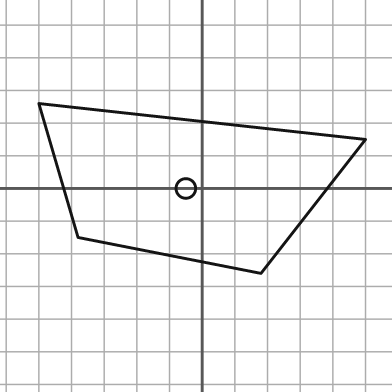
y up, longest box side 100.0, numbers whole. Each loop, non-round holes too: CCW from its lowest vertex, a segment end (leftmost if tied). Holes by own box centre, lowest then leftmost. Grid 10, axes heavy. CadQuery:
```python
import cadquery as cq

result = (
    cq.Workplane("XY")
    .moveTo(18.0, -26.0)
    .lineTo(50.0, 15.0)
    .lineTo(-50.0, 26.0)
    .lineTo(-38.0, -15.0)
    .close()
    .moveTo(-5.0, 0.0)
    .circle(3.0)
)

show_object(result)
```